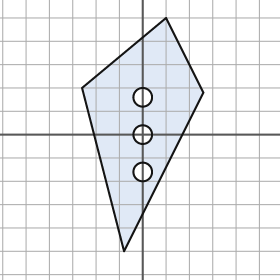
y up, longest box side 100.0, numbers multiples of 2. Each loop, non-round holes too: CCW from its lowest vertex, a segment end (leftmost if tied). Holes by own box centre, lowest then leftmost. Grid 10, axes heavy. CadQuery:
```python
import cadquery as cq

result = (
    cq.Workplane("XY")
    .moveTo(-8.0, -50.0)
    .lineTo(26.0, 18.0)
    .lineTo(10.0, 50.0)
    .lineTo(-26.0, 20.0)
    .close()
    .moveTo(0.0, -16.0)
    .circle(4.0)
    .moveTo(0.0, 0.0)
    .circle(4.0)
    .moveTo(0.0, 16.0)
    .circle(4.0)
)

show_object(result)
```